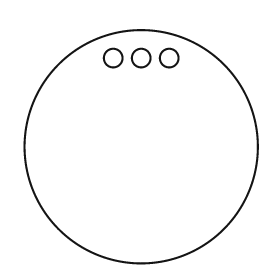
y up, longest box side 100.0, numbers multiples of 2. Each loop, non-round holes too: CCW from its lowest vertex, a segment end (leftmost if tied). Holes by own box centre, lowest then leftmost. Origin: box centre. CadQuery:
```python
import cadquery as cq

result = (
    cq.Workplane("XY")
    .moveTo(0.0, 0.0)
    .circle(50.0)
    .moveTo(-12.0, 38.0)
    .circle(4.0)
    .moveTo(0.0, 38.0)
    .circle(4.0)
    .moveTo(12.0, 38.0)
    .circle(4.0)
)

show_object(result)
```